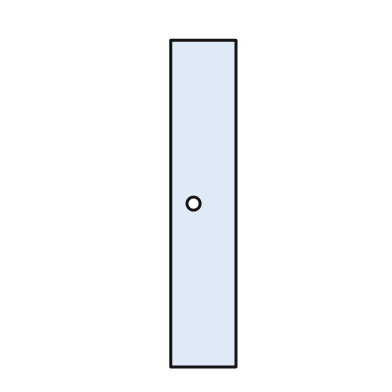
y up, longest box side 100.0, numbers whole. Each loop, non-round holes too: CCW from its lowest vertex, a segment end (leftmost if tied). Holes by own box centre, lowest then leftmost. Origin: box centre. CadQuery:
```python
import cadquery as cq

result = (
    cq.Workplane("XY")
    .moveTo(-10.0, -50.0)
    .lineTo(10.0, -50.0)
    .lineTo(10.0, 50.0)
    .lineTo(-10.0, 50.0)
    .close()
    .moveTo(-3.0, 0.0)
    .circle(2.0)
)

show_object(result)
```